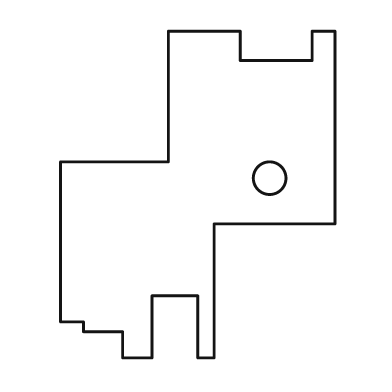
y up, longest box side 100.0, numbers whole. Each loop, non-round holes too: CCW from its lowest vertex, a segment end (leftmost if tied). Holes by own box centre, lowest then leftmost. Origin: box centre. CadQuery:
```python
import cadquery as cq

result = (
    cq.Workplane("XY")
    .moveTo(-23.0, -50.0)
    .lineTo(-14.0, -50.0)
    .lineTo(-14.0, -31.0)
    .lineTo(0.0, -31.0)
    .lineTo(0.0, -50.0)
    .lineTo(5.0, -50.0)
    .lineTo(5.0, -9.0)
    .lineTo(42.0, -9.0)
    .lineTo(42.0, 50.0)
    .lineTo(35.0, 50.0)
    .lineTo(35.0, 41.0)
    .lineTo(13.0, 41.0)
    .lineTo(13.0, 50.0)
    .lineTo(-9.0, 50.0)
    .lineTo(-9.0, 10.0)
    .lineTo(-42.0, 10.0)
    .lineTo(-42.0, -39.0)
    .lineTo(-35.0, -39.0)
    .lineTo(-35.0, -42.0)
    .lineTo(-23.0, -42.0)
    .close()
    .moveTo(22.0, 5.0)
    .circle(5.0)
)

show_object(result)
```